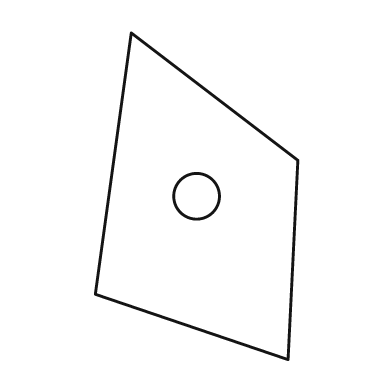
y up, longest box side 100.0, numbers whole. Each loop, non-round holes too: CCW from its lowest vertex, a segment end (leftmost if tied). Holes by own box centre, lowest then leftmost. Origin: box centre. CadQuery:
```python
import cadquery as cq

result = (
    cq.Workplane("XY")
    .moveTo(28.0, -50.0)
    .lineTo(31.0, 11.0)
    .lineTo(-20.0, 50.0)
    .lineTo(-31.0, -30.0)
    .close()
    .moveTo(0.0, 0.0)
    .circle(7.0)
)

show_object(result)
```